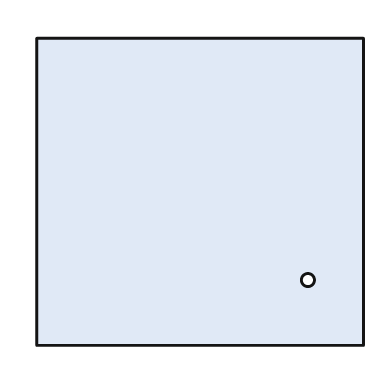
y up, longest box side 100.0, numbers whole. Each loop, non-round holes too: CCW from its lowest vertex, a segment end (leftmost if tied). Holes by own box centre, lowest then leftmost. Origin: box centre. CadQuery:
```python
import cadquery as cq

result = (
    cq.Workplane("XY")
    .moveTo(-50.0, -47.0)
    .lineTo(50.0, -47.0)
    .lineTo(50.0, 47.0)
    .lineTo(-50.0, 47.0)
    .close()
    .moveTo(33.0, -27.0)
    .circle(2.0)
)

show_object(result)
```